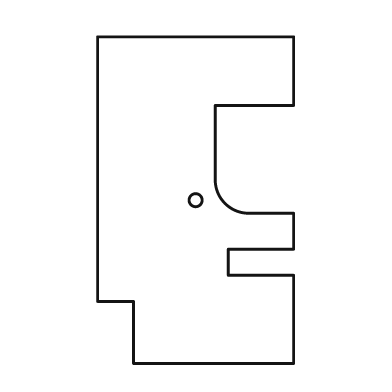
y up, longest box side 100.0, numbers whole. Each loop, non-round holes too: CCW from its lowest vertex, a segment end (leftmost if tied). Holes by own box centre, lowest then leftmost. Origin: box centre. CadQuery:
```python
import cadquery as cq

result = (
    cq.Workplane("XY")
    .moveTo(-19.0, -50.0)
    .lineTo(30.0, -50.0)
    .lineTo(30.0, -23.0)
    .lineTo(10.0, -23.0)
    .lineTo(10.0, -15.0)
    .lineTo(30.0, -15.0)
    .lineTo(30.0, -4.0)
    .lineTo(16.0, -4.0)
    .threePointArc((9.0, -1.0), (6.0, 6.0))
    .lineTo(6.0, 29.0)
    .lineTo(30.0, 29.0)
    .lineTo(30.0, 50.0)
    .lineTo(-30.0, 50.0)
    .lineTo(-30.0, -31.0)
    .lineTo(-19.0, -31.0)
    .close()
    .moveTo(0.0, 0.0)
    .circle(2.0)
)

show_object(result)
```